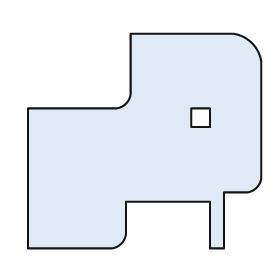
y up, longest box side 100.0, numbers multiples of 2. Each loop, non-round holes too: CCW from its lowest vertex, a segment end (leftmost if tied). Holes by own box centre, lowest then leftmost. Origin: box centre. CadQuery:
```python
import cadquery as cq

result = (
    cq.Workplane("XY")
    .moveTo(-50.0, -46.0)
    .lineTo(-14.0, -46.0)
    .threePointArc((-10.0, -44.0), (-8.0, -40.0))
    .lineTo(-8.0, -26.0)
    .lineTo(28.0, -26.0)
    .lineTo(28.0, -46.0)
    .lineTo(34.0, -46.0)
    .lineTo(34.0, -22.0)
    .lineTo(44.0, -22.0)
    .threePointArc((48.0, -20.0), (50.0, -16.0))
    .lineTo(50.0, 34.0)
    .threePointArc((46.0, 42.0), (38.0, 46.0))
    .lineTo(-6.0, 46.0)
    .lineTo(-6.0, 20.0)
    .threePointArc((-8.0, 16.0), (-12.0, 14.0))
    .lineTo(-50.0, 14.0)
    .close()
    .moveTo(20.0, 6.0)
    .lineTo(28.0, 6.0)
    .lineTo(28.0, 14.0)
    .lineTo(20.0, 14.0)
    .close()
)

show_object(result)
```